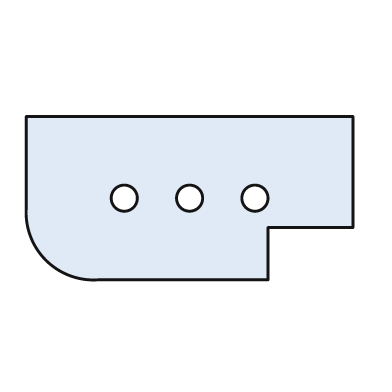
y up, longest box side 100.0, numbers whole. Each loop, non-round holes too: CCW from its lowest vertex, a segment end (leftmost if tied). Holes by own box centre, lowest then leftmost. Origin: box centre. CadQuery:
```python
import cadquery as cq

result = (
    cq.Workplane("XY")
    .moveTo(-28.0, -25.0)
    .lineTo(24.0, -25.0)
    .lineTo(24.0, -9.0)
    .lineTo(50.0, -9.0)
    .lineTo(50.0, 25.0)
    .lineTo(-50.0, 25.0)
    .lineTo(-50.0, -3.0)
    .threePointArc((-44.0, -19.0), (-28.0, -25.0))
    .close()
    .moveTo(-20.0, 0.0)
    .circle(4.0)
    .moveTo(0.0, 0.0)
    .circle(4.0)
    .moveTo(20.0, 0.0)
    .circle(4.0)
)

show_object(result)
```